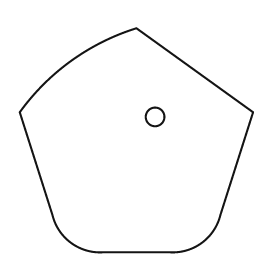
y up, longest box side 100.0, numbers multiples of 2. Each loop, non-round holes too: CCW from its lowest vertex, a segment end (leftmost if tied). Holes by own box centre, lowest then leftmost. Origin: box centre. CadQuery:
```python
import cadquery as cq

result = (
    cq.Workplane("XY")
    .moveTo(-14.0, -48.0)
    .lineTo(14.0, -48.0)
    .threePointArc((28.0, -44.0), (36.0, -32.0))
    .lineTo(50.0, 12.0)
    .lineTo(0.0, 48.0)
    .threePointArc((-28.0, 34.0), (-50.0, 12.0))
    .lineTo(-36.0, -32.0)
    .threePointArc((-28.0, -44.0), (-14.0, -48.0))
    .close()
    .moveTo(8.0, 10.0)
    .circle(4.0)
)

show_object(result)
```